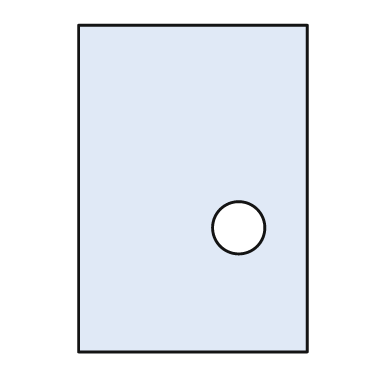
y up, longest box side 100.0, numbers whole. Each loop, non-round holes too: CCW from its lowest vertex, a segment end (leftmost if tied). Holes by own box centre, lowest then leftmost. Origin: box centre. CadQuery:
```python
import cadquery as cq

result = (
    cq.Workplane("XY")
    .moveTo(-35.0, -50.0)
    .lineTo(35.0, -50.0)
    .lineTo(35.0, 50.0)
    .lineTo(-35.0, 50.0)
    .close()
    .moveTo(14.0, -12.0)
    .circle(8.0)
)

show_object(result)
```